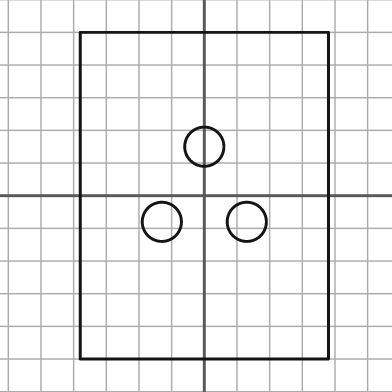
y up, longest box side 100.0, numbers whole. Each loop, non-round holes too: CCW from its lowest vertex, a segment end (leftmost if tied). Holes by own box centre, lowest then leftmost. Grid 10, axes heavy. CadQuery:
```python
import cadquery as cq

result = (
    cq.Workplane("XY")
    .moveTo(-38.0, -50.0)
    .lineTo(38.0, -50.0)
    .lineTo(38.0, 50.0)
    .lineTo(-38.0, 50.0)
    .close()
    .moveTo(-13.0, -8.0)
    .circle(6.0)
    .moveTo(13.0, -8.0)
    .circle(6.0)
    .moveTo(0.0, 15.0)
    .circle(6.0)
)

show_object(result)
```